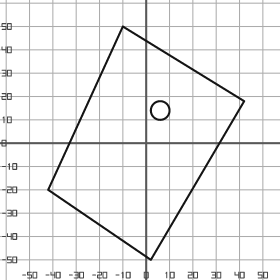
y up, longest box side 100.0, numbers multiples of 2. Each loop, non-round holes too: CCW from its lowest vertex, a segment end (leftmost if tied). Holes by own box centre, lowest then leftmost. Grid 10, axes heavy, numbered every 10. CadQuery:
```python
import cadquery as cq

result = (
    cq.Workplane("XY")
    .moveTo(2.0, -50.0)
    .lineTo(42.0, 18.0)
    .lineTo(-10.0, 50.0)
    .lineTo(-42.0, -20.0)
    .close()
    .moveTo(6.0, 14.0)
    .circle(4.0)
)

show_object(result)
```